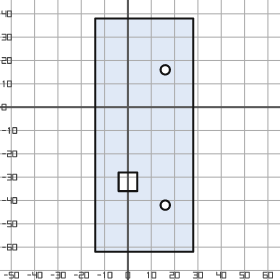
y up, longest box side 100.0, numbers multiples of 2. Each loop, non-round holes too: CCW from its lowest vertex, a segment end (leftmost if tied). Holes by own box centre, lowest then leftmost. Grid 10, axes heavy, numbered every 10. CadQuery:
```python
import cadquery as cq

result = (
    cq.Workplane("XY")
    .moveTo(-14.0, -62.0)
    .lineTo(28.0, -62.0)
    .lineTo(28.0, 38.0)
    .lineTo(-14.0, 38.0)
    .close()
    .moveTo(16.0, -42.0)
    .circle(2.0)
    .moveTo(-4.0, -36.0)
    .lineTo(4.0, -36.0)
    .lineTo(4.0, -28.0)
    .lineTo(-4.0, -28.0)
    .close()
    .moveTo(16.0, 16.0)
    .circle(2.0)
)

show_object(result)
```